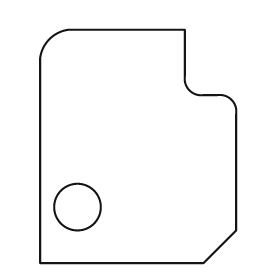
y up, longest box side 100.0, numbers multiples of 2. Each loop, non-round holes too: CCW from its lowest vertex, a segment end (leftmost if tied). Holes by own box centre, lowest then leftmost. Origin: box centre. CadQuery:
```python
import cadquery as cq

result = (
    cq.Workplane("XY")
    .moveTo(-42.0, -50.0)
    .lineTo(28.0, -50.0)
    .lineTo(42.0, -36.0)
    .lineTo(42.0, 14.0)
    .threePointArc((40.0, 20.0), (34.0, 22.0))
    .lineTo(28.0, 22.0)
    .threePointArc((22.0, 24.0), (20.0, 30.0))
    .lineTo(20.0, 50.0)
    .lineTo(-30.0, 50.0)
    .threePointArc((-38.0, 46.0), (-42.0, 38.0))
    .close()
    .moveTo(-26.0, -26.0)
    .circle(10.0)
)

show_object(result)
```